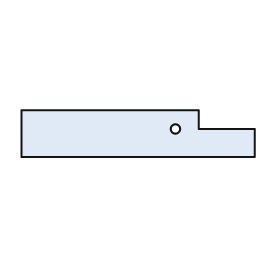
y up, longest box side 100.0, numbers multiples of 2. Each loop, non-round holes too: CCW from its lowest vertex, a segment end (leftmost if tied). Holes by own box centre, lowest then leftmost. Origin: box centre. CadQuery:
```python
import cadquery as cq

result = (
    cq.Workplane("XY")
    .moveTo(-50.0, -10.0)
    .lineTo(50.0, -10.0)
    .lineTo(50.0, 2.0)
    .lineTo(26.0, 2.0)
    .lineTo(26.0, 10.0)
    .lineTo(-50.0, 10.0)
    .close()
    .moveTo(16.0, 2.0)
    .circle(2.0)
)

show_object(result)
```